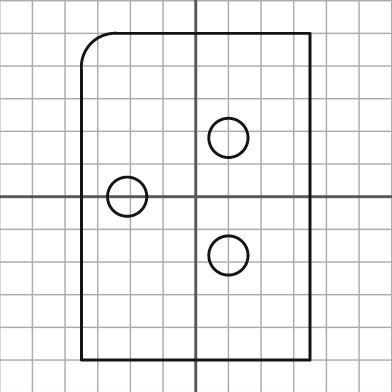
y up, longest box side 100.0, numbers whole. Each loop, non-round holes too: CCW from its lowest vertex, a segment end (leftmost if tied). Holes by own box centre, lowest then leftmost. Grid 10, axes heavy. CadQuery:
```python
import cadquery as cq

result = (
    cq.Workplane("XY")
    .moveTo(-35.0, -50.0)
    .lineTo(35.0, -50.0)
    .lineTo(35.0, 50.0)
    .lineTo(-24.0, 50.0)
    .threePointArc((-32.0, 47.0), (-35.0, 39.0))
    .close()
    .moveTo(10.0, -18.0)
    .circle(6.0)
    .moveTo(-21.0, 0.0)
    .circle(6.0)
    .moveTo(10.0, 18.0)
    .circle(6.0)
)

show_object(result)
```